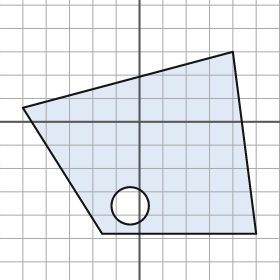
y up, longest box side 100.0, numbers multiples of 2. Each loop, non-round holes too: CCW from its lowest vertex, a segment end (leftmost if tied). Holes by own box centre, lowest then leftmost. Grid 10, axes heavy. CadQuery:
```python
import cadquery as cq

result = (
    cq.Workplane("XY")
    .moveTo(-16.0, -48.0)
    .lineTo(50.0, -48.0)
    .lineTo(40.0, 30.0)
    .lineTo(-50.0, 6.0)
    .close()
    .moveTo(-4.0, -36.0)
    .circle(8.0)
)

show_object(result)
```